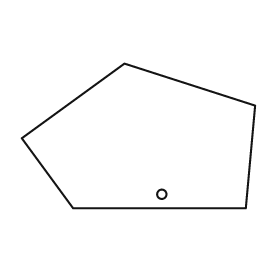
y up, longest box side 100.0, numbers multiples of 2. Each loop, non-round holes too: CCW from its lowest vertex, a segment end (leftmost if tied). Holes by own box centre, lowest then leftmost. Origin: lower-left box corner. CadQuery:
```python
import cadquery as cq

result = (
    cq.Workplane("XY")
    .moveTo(22.0, 0.0)
    .lineTo(96.0, 0.0)
    .lineTo(100.0, 44.0)
    .lineTo(44.0, 62.0)
    .lineTo(0.0, 30.0)
    .close()
    .moveTo(60.0, 6.0)
    .circle(2.0)
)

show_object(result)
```